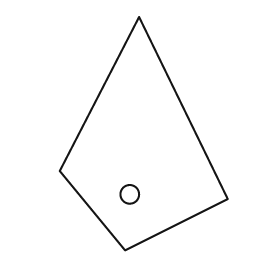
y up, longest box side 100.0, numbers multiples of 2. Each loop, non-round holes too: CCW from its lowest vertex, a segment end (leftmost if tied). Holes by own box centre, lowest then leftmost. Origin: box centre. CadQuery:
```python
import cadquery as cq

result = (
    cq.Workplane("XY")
    .moveTo(-8.0, -50.0)
    .lineTo(36.0, -28.0)
    .lineTo(-2.0, 50.0)
    .lineTo(-36.0, -16.0)
    .close()
    .moveTo(-6.0, -26.0)
    .circle(4.0)
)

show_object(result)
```